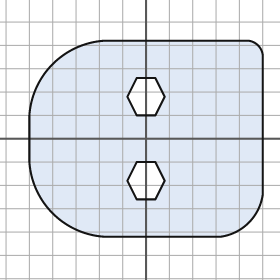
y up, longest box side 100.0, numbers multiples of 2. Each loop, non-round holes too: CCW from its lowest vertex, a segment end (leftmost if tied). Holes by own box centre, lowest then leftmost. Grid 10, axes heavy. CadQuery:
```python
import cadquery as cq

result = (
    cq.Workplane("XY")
    .moveTo(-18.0, -42.0)
    .lineTo(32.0, -42.0)
    .threePointArc((44.0, -36.0), (50.0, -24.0))
    .lineTo(50.0, 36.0)
    .threePointArc((48.0, 40.0), (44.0, 42.0))
    .lineTo(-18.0, 42.0)
    .threePointArc((-40.0, 32.0), (-50.0, 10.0))
    .lineTo(-50.0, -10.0)
    .threePointArc((-40.0, -32.0), (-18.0, -42.0))
    .close()
    .moveTo(-4.0, -26.0)
    .lineTo(4.0, -26.0)
    .lineTo(8.0, -18.0)
    .lineTo(4.0, -10.0)
    .lineTo(-4.0, -10.0)
    .lineTo(-8.0, -18.0)
    .close()
    .moveTo(-4.0, 10.0)
    .lineTo(4.0, 10.0)
    .lineTo(8.0, 18.0)
    .lineTo(4.0, 26.0)
    .lineTo(-4.0, 26.0)
    .lineTo(-8.0, 18.0)
    .close()
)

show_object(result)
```